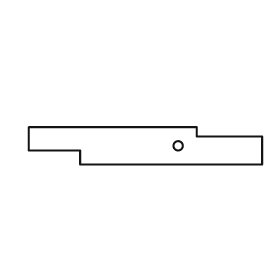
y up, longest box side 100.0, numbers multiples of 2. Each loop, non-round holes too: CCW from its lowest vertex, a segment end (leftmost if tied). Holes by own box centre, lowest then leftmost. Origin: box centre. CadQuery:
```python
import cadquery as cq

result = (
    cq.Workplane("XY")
    .moveTo(-28.0, -8.0)
    .lineTo(50.0, -8.0)
    .lineTo(50.0, 4.0)
    .lineTo(22.0, 4.0)
    .lineTo(22.0, 8.0)
    .lineTo(-50.0, 8.0)
    .lineTo(-50.0, -2.0)
    .lineTo(-28.0, -2.0)
    .close()
    .moveTo(14.0, 0.0)
    .circle(2.0)
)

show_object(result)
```